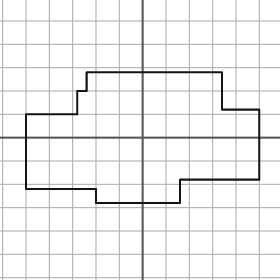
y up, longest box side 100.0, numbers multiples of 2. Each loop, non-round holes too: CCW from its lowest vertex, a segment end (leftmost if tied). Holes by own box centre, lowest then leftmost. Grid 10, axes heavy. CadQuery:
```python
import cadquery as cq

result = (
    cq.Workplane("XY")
    .moveTo(-20.0, -28.0)
    .lineTo(16.0, -28.0)
    .lineTo(16.0, -18.0)
    .lineTo(50.0, -18.0)
    .lineTo(50.0, 12.0)
    .lineTo(34.0, 12.0)
    .lineTo(34.0, 28.0)
    .lineTo(-24.0, 28.0)
    .lineTo(-24.0, 20.0)
    .lineTo(-28.0, 20.0)
    .lineTo(-28.0, 10.0)
    .lineTo(-50.0, 10.0)
    .lineTo(-50.0, -22.0)
    .lineTo(-20.0, -22.0)
    .close()
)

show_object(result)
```